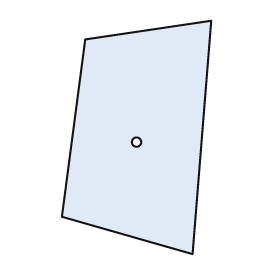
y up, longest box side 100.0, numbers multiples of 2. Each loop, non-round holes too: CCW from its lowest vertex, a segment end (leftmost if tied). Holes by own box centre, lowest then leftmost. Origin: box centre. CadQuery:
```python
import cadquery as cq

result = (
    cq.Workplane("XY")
    .moveTo(24.0, -50.0)
    .lineTo(32.0, 50.0)
    .lineTo(-22.0, 42.0)
    .lineTo(-32.0, -34.0)
    .close()
    .moveTo(0.0, -2.0)
    .circle(2.0)
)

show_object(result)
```